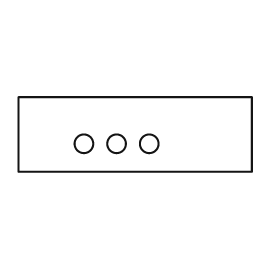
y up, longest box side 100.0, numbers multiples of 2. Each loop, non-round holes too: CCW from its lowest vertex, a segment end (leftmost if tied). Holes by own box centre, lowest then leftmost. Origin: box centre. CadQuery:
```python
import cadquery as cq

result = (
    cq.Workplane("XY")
    .moveTo(-50.0, -16.0)
    .lineTo(50.0, -16.0)
    .lineTo(50.0, 16.0)
    .lineTo(-50.0, 16.0)
    .close()
    .moveTo(-22.0, -4.0)
    .circle(4.0)
    .moveTo(-8.0, -4.0)
    .circle(4.0)
    .moveTo(6.0, -4.0)
    .circle(4.0)
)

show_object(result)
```